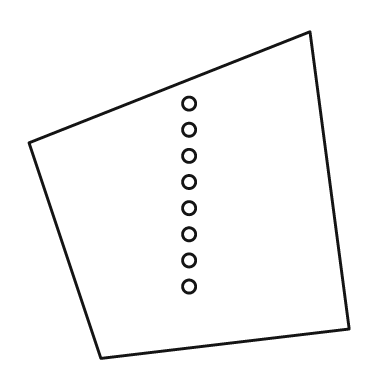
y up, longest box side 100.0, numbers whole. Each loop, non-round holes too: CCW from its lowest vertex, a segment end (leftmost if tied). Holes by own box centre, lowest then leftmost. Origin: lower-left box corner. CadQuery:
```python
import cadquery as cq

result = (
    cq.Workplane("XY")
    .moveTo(22.0, 0.0)
    .lineTo(98.0, 9.0)
    .lineTo(86.0, 100.0)
    .lineTo(0.0, 66.0)
    .close()
    .moveTo(49.0, 22.0)
    .circle(2.0)
    .moveTo(49.0, 30.0)
    .circle(2.0)
    .moveTo(49.0, 38.0)
    .circle(2.0)
    .moveTo(49.0, 46.0)
    .circle(2.0)
    .moveTo(49.0, 54.0)
    .circle(2.0)
    .moveTo(49.0, 62.0)
    .circle(2.0)
    .moveTo(49.0, 70.0)
    .circle(2.0)
    .moveTo(49.0, 78.0)
    .circle(2.0)
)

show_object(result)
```